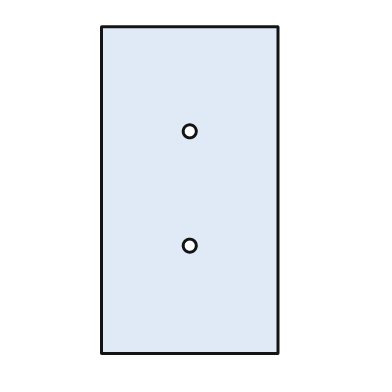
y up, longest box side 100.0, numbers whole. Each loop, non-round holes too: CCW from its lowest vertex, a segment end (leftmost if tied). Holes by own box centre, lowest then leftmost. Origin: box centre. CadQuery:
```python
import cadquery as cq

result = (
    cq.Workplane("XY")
    .moveTo(-27.0, -50.0)
    .lineTo(27.0, -50.0)
    .lineTo(27.0, 50.0)
    .lineTo(-27.0, 50.0)
    .close()
    .moveTo(0.0, -17.0)
    .circle(2.0)
    .moveTo(0.0, 18.0)
    .circle(2.0)
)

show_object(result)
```